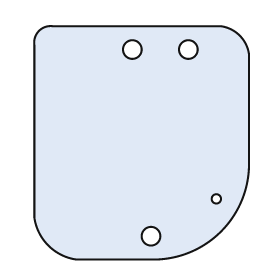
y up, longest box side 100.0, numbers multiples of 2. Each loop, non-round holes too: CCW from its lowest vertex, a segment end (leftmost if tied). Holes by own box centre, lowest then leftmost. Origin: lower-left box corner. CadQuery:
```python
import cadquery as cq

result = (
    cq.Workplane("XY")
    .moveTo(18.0, 0.0)
    .lineTo(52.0, 0.0)
    .threePointArc((80.0, 12.0), (92.0, 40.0))
    .lineTo(92.0, 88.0)
    .threePointArc((88.0, 96.0), (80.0, 100.0))
    .lineTo(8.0, 100.0)
    .threePointArc((2.0, 98.0), (0.0, 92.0))
    .lineTo(0.0, 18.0)
    .threePointArc((6.0, 6.0), (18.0, 0.0))
    .close()
    .moveTo(50.0, 10.0)
    .circle(4.0)
    .moveTo(78.0, 26.0)
    .circle(2.0)
    .moveTo(42.0, 90.0)
    .circle(4.0)
    .moveTo(66.0, 90.0)
    .circle(4.0)
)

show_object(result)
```